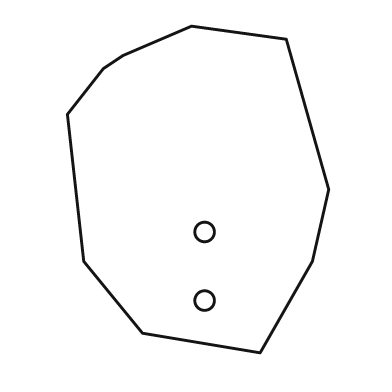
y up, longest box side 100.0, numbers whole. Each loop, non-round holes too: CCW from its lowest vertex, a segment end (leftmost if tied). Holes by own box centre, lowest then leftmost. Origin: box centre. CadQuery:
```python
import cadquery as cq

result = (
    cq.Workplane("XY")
    .moveTo(19.0, -50.0)
    .lineTo(35.0, -22.0)
    .lineTo(40.0, 0.0)
    .lineTo(27.0, 46.0)
    .lineTo(-2.0, 50.0)
    .lineTo(-23.0, 41.0)
    .lineTo(-29.0, 37.0)
    .lineTo(-40.0, 23.0)
    .lineTo(-35.0, -22.0)
    .lineTo(-17.0, -44.0)
    .close()
    .moveTo(2.0, -34.0)
    .circle(3.0)
    .moveTo(2.0, -13.0)
    .circle(3.0)
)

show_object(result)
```